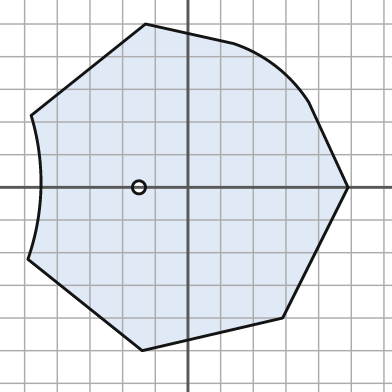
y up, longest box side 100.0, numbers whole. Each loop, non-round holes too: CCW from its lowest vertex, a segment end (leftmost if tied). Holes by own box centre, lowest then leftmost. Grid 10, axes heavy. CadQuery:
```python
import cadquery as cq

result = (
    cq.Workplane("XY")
    .moveTo(-14.0, -50.0)
    .lineTo(29.0, -40.0)
    .lineTo(49.0, 0.0)
    .lineTo(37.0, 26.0)
    .threePointArc((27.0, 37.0), (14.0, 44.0))
    .lineTo(-13.0, 50.0)
    .lineTo(-48.0, 22.0)
    .threePointArc((-45.0, 0.0), (-49.0, -22.0))
    .close()
    .moveTo(-15.0, 0.0)
    .circle(2.0)
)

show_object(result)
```